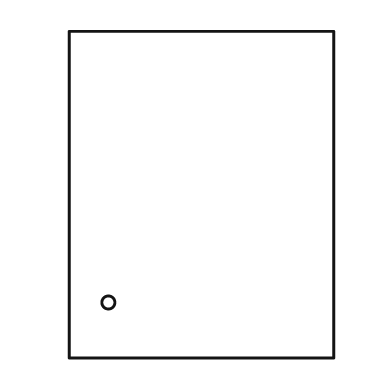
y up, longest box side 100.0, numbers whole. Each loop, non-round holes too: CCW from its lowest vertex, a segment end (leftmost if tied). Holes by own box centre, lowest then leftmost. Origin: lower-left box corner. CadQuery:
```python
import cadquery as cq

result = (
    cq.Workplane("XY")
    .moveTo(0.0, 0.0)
    .lineTo(81.0, 0.0)
    .lineTo(81.0, 100.0)
    .lineTo(0.0, 100.0)
    .close()
    .moveTo(12.0, 17.0)
    .circle(2.0)
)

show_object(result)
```